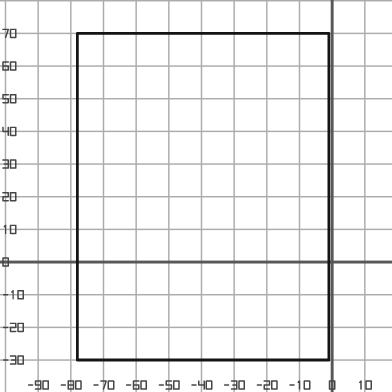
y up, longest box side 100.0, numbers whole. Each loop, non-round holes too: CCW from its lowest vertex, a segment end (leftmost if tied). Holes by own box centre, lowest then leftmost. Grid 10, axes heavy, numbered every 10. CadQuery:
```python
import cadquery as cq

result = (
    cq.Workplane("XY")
    .moveTo(-78.0, -30.0)
    .lineTo(-1.0, -30.0)
    .lineTo(-1.0, 70.0)
    .lineTo(-78.0, 70.0)
    .close()
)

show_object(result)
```